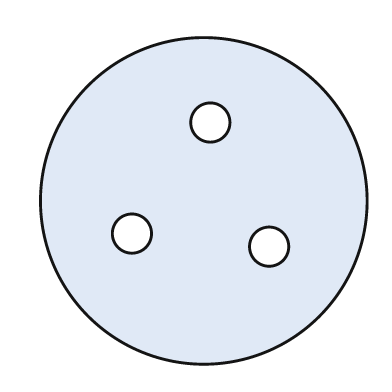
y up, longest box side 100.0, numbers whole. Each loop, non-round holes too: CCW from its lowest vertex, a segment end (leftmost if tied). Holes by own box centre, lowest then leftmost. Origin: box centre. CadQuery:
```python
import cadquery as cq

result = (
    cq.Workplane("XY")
    .moveTo(0.0, 0.0)
    .circle(50.0)
    .moveTo(20.0, -14.0)
    .circle(6.0)
    .moveTo(-22.0, -10.0)
    .circle(6.0)
    .moveTo(2.0, 24.0)
    .circle(6.0)
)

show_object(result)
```